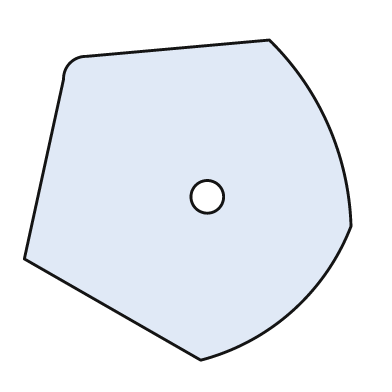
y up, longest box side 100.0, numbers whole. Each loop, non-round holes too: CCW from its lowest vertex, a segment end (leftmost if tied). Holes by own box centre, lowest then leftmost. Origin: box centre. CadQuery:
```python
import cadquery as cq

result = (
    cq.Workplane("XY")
    .moveTo(4.0, -49.0)
    .threePointArc((32.0, -34.0), (50.0, -8.0))
    .threePointArc((43.0, 23.0), (25.0, 49.0))
    .lineTo(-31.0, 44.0)
    .threePointArc((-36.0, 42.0), (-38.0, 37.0))
    .lineTo(-50.0, -18.0)
    .close()
    .moveTo(6.0, 1.0)
    .circle(5.0)
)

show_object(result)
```